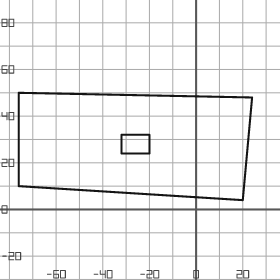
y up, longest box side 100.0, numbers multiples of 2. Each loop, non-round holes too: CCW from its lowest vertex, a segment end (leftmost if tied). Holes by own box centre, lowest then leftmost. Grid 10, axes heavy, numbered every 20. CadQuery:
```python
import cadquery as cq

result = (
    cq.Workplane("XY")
    .moveTo(20.0, 4.0)
    .lineTo(24.0, 48.0)
    .lineTo(-76.0, 50.0)
    .lineTo(-76.0, 10.0)
    .close()
    .moveTo(-32.0, 24.0)
    .lineTo(-20.0, 24.0)
    .lineTo(-20.0, 32.0)
    .lineTo(-32.0, 32.0)
    .close()
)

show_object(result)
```